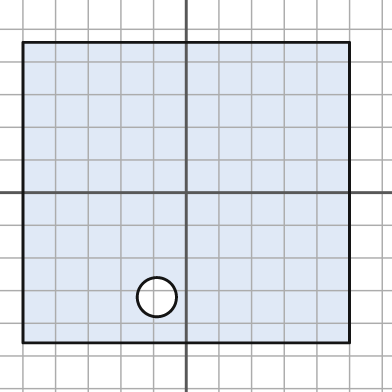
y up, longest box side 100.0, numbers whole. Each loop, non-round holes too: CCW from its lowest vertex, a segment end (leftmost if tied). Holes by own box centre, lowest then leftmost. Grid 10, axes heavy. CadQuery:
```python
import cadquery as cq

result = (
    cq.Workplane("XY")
    .moveTo(-50.0, -46.0)
    .lineTo(50.0, -46.0)
    .lineTo(50.0, 46.0)
    .lineTo(-50.0, 46.0)
    .close()
    .moveTo(-9.0, -32.0)
    .circle(6.0)
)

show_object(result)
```